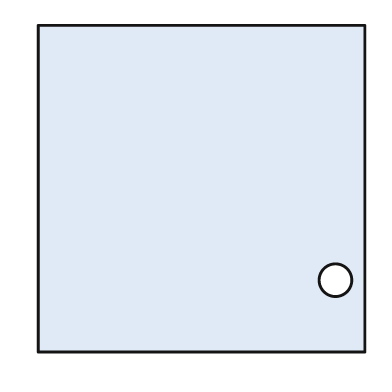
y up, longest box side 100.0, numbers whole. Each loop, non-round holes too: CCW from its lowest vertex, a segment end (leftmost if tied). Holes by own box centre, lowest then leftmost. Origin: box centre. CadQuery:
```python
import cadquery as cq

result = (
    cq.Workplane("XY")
    .moveTo(-50.0, -50.0)
    .lineTo(50.0, -50.0)
    .lineTo(50.0, 50.0)
    .lineTo(-50.0, 50.0)
    .close()
    .moveTo(41.0, -28.0)
    .circle(5.0)
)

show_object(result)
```